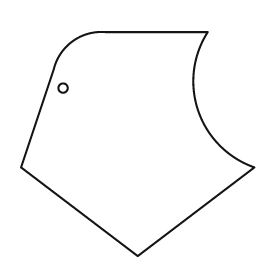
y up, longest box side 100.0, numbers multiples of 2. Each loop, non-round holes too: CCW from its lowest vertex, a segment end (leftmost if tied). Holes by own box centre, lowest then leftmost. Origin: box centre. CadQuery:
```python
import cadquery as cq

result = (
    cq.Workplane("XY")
    .moveTo(0.0, -48.0)
    .lineTo(50.0, -10.0)
    .threePointArc((26.0, 14.0), (30.0, 48.0))
    .lineTo(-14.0, 48.0)
    .threePointArc((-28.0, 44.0), (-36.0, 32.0))
    .lineTo(-50.0, -10.0)
    .close()
    .moveTo(-32.0, 24.0)
    .circle(2.0)
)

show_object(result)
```